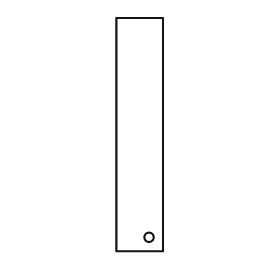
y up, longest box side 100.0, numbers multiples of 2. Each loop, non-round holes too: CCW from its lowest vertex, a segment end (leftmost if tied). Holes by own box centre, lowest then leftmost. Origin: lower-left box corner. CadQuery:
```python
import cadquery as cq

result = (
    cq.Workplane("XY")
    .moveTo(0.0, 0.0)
    .lineTo(20.0, 0.0)
    .lineTo(20.0, 100.0)
    .lineTo(0.0, 100.0)
    .close()
    .moveTo(14.0, 6.0)
    .circle(2.0)
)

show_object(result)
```